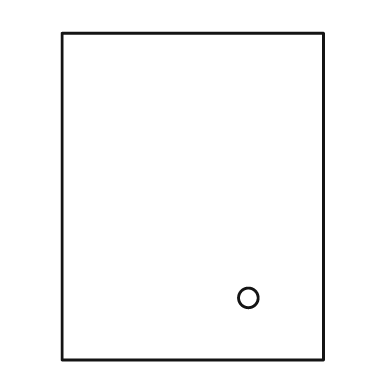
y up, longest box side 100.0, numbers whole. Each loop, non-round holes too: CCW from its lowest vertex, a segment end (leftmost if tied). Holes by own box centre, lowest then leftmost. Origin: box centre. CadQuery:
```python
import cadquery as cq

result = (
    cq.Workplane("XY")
    .moveTo(-40.0, -50.0)
    .lineTo(40.0, -50.0)
    .lineTo(40.0, 50.0)
    .lineTo(-40.0, 50.0)
    .close()
    .moveTo(17.0, -31.0)
    .circle(3.0)
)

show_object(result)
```